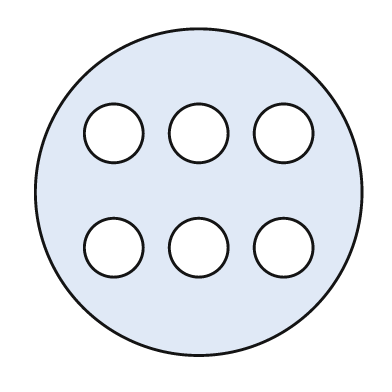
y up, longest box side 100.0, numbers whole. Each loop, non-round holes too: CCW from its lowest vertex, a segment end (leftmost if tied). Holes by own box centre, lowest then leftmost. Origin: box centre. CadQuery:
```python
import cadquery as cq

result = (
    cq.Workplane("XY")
    .moveTo(0.0, 0.0)
    .circle(50.0)
    .moveTo(-26.0, -17.0)
    .circle(9.0)
    .moveTo(0.0, -17.0)
    .circle(9.0)
    .moveTo(26.0, -17.0)
    .circle(9.0)
    .moveTo(-26.0, 18.0)
    .circle(9.0)
    .moveTo(0.0, 18.0)
    .circle(9.0)
    .moveTo(26.0, 18.0)
    .circle(9.0)
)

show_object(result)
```